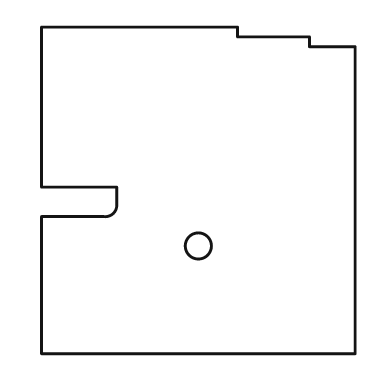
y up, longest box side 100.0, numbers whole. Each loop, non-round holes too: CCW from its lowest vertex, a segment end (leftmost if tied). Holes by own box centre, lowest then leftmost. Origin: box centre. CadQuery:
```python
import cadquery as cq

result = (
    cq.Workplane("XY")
    .moveTo(-48.0, -50.0)
    .lineTo(48.0, -50.0)
    .lineTo(48.0, 44.0)
    .lineTo(34.0, 44.0)
    .lineTo(34.0, 47.0)
    .lineTo(12.0, 47.0)
    .lineTo(12.0, 50.0)
    .lineTo(-48.0, 50.0)
    .lineTo(-48.0, 1.0)
    .lineTo(-25.0, 1.0)
    .lineTo(-25.0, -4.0)
    .threePointArc((-26.0, -7.0), (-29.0, -8.0))
    .lineTo(-48.0, -8.0)
    .close()
    .moveTo(0.0, -17.0)
    .circle(4.0)
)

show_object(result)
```